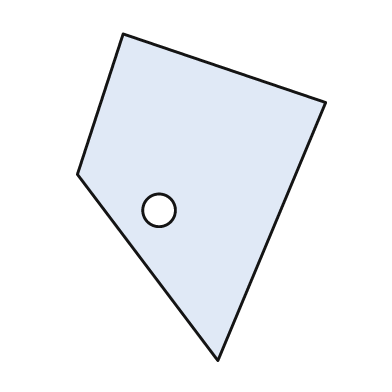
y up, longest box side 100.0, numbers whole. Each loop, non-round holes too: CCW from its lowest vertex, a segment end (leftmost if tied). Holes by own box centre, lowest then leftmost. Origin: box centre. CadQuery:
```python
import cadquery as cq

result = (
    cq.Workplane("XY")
    .moveTo(5.0, -50.0)
    .lineTo(38.0, 29.0)
    .lineTo(-24.0, 50.0)
    .lineTo(-38.0, 7.0)
    .close()
    .moveTo(-13.0, -4.0)
    .circle(5.0)
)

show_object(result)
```